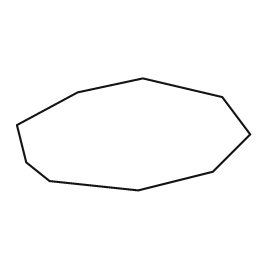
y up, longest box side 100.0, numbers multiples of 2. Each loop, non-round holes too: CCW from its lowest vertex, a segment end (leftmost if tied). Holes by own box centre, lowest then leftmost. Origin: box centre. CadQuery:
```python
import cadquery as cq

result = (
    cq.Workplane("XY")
    .moveTo(2.0, -24.0)
    .lineTo(34.0, -16.0)
    .lineTo(50.0, 0.0)
    .lineTo(38.0, 16.0)
    .lineTo(4.0, 24.0)
    .lineTo(-24.0, 18.0)
    .lineTo(-50.0, 4.0)
    .lineTo(-46.0, -12.0)
    .lineTo(-36.0, -20.0)
    .close()
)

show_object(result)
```